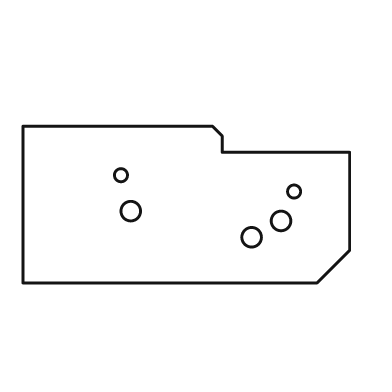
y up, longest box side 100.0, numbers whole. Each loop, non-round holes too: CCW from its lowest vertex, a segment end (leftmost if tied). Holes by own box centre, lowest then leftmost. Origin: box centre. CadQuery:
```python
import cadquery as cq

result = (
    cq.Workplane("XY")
    .moveTo(-50.0, -24.0)
    .lineTo(40.0, -24.0)
    .lineTo(50.0, -14.0)
    .lineTo(50.0, 16.0)
    .lineTo(11.0, 16.0)
    .lineTo(11.0, 21.0)
    .lineTo(8.0, 24.0)
    .lineTo(-50.0, 24.0)
    .close()
    .moveTo(20.0, -10.0)
    .circle(3.0)
    .moveTo(29.0, -5.0)
    .circle(3.0)
    .moveTo(-17.0, -2.0)
    .circle(3.0)
    .moveTo(33.0, 4.0)
    .circle(2.0)
    .moveTo(-20.0, 9.0)
    .circle(2.0)
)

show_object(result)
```